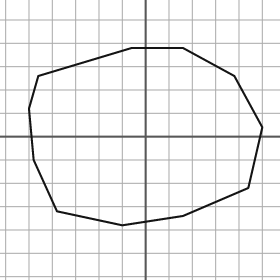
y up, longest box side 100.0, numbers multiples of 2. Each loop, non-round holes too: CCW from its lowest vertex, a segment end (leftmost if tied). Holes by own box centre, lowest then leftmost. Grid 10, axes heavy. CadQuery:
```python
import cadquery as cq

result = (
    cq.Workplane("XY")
    .moveTo(-10.0, -38.0)
    .lineTo(16.0, -34.0)
    .lineTo(44.0, -22.0)
    .lineTo(50.0, 4.0)
    .lineTo(38.0, 26.0)
    .lineTo(16.0, 38.0)
    .lineTo(-6.0, 38.0)
    .lineTo(-46.0, 26.0)
    .lineTo(-50.0, 12.0)
    .lineTo(-48.0, -10.0)
    .lineTo(-38.0, -32.0)
    .close()
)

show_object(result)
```